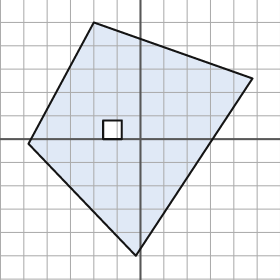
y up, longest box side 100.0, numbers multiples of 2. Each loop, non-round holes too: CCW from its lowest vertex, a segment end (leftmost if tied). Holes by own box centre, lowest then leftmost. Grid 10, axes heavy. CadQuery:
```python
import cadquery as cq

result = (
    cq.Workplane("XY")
    .moveTo(-2.0, -50.0)
    .lineTo(48.0, 26.0)
    .lineTo(-20.0, 50.0)
    .lineTo(-48.0, -2.0)
    .close()
    .moveTo(-16.0, 0.0)
    .lineTo(-8.0, 0.0)
    .lineTo(-8.0, 8.0)
    .lineTo(-16.0, 8.0)
    .close()
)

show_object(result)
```